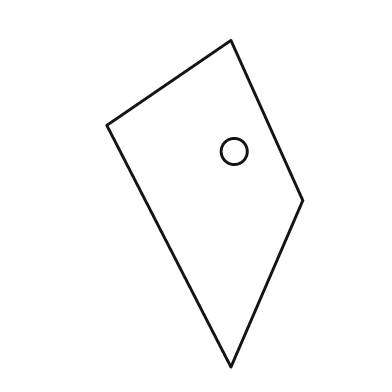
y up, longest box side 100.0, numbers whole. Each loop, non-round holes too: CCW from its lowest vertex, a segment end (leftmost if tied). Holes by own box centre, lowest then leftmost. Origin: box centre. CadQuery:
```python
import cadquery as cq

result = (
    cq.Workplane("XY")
    .moveTo(8.0, -50.0)
    .lineTo(30.0, 1.0)
    .lineTo(8.0, 50.0)
    .lineTo(-30.0, 24.0)
    .close()
    .moveTo(9.0, 16.0)
    .circle(4.0)
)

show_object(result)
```